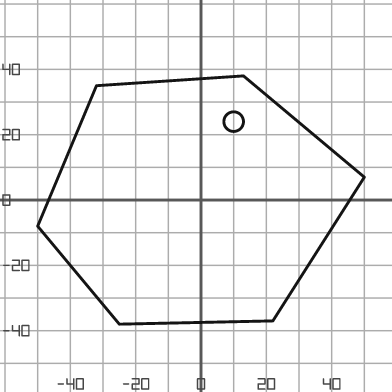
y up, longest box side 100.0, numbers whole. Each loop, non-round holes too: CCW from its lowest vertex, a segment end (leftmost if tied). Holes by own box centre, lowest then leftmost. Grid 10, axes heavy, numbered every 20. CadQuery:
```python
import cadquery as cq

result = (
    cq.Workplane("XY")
    .moveTo(-25.0, -38.0)
    .lineTo(22.0, -37.0)
    .lineTo(50.0, 7.0)
    .lineTo(13.0, 38.0)
    .lineTo(-32.0, 35.0)
    .lineTo(-50.0, -8.0)
    .close()
    .moveTo(10.0, 24.0)
    .circle(3.0)
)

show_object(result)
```